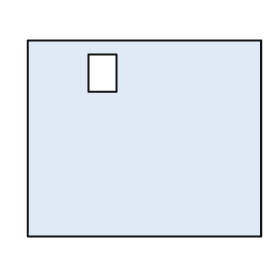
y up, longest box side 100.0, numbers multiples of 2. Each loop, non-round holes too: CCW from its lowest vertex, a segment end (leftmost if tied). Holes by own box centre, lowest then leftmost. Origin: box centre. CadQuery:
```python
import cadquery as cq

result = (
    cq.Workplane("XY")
    .moveTo(-50.0, -42.0)
    .lineTo(50.0, -42.0)
    .lineTo(50.0, 42.0)
    .lineTo(-50.0, 42.0)
    .close()
    .moveTo(-24.0, 20.0)
    .lineTo(-12.0, 20.0)
    .lineTo(-12.0, 36.0)
    .lineTo(-24.0, 36.0)
    .close()
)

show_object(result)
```